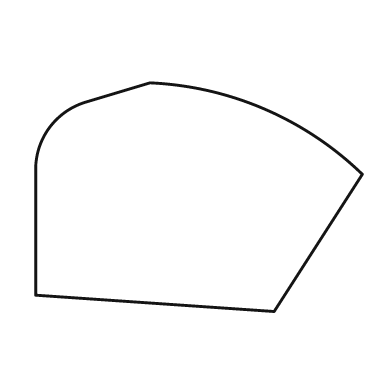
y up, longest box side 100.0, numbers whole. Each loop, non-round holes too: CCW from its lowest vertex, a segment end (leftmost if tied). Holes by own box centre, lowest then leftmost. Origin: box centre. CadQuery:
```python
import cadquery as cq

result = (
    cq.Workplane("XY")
    .moveTo(23.0, -35.0)
    .lineTo(50.0, 7.0)
    .threePointArc((20.0, 27.0), (-15.0, 35.0))
    .lineTo(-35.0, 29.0)
    .threePointArc((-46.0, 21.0), (-50.0, 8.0))
    .lineTo(-50.0, -30.0)
    .close()
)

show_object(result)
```